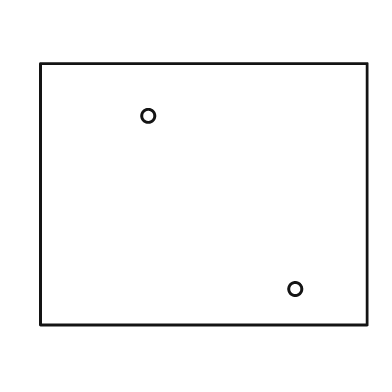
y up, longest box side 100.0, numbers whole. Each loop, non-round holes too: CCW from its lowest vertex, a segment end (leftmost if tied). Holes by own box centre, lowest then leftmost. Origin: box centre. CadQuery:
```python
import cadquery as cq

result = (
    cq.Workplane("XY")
    .moveTo(-50.0, -40.0)
    .lineTo(50.0, -40.0)
    .lineTo(50.0, 40.0)
    .lineTo(-50.0, 40.0)
    .close()
    .moveTo(28.0, -29.0)
    .circle(2.0)
    .moveTo(-17.0, 24.0)
    .circle(2.0)
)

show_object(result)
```